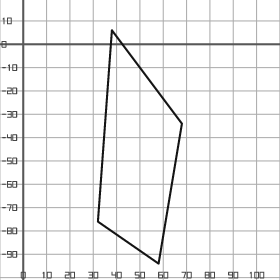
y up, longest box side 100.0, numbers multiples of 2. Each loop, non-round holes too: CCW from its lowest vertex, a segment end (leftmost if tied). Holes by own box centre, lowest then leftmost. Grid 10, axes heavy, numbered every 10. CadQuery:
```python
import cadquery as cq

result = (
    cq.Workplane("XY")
    .moveTo(58.0, -94.0)
    .lineTo(68.0, -34.0)
    .lineTo(38.0, 6.0)
    .lineTo(32.0, -76.0)
    .close()
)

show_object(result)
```